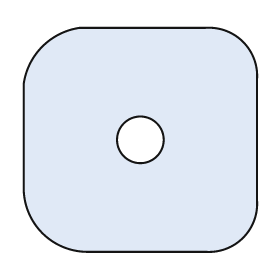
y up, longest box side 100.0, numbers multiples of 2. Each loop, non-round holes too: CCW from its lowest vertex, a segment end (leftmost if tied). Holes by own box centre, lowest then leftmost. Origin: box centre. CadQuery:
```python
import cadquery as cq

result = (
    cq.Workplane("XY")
    .moveTo(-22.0, -48.0)
    .lineTo(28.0, -48.0)
    .threePointArc((44.0, -42.0), (50.0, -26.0))
    .lineTo(50.0, 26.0)
    .threePointArc((44.0, 42.0), (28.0, 48.0))
    .lineTo(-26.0, 48.0)
    .threePointArc((-42.0, 40.0), (-50.0, 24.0))
    .lineTo(-50.0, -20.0)
    .threePointArc((-42.0, -40.0), (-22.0, -48.0))
    .close()
    .moveTo(0.0, 0.0)
    .circle(10.0)
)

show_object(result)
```